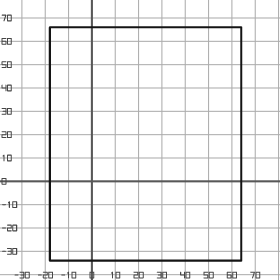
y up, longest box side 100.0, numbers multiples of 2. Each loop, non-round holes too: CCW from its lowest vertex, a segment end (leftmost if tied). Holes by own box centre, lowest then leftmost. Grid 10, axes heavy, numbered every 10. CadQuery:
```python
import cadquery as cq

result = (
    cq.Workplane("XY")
    .moveTo(-18.0, -34.0)
    .lineTo(64.0, -34.0)
    .lineTo(64.0, 66.0)
    .lineTo(-18.0, 66.0)
    .close()
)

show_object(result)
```